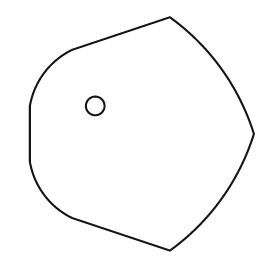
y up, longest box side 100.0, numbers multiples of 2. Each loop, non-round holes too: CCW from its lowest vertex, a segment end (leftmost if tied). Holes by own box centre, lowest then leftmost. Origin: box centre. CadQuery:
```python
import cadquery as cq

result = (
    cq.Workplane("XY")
    .moveTo(12.0, -50.0)
    .threePointArc((34.0, -28.0), (48.0, 0.0))
    .threePointArc((34.0, 28.0), (12.0, 50.0))
    .lineTo(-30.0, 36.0)
    .threePointArc((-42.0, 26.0), (-48.0, 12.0))
    .lineTo(-48.0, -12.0)
    .threePointArc((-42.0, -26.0), (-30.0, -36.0))
    .close()
    .moveTo(-20.0, 12.0)
    .circle(4.0)
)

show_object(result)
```